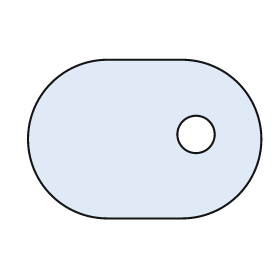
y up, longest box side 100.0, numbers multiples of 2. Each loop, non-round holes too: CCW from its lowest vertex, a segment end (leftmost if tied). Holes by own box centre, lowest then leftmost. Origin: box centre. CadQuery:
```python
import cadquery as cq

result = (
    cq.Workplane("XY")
    .moveTo(-16.0, -34.0)
    .lineTo(16.0, -34.0)
    .threePointArc((50.0, 0.0), (16.0, 34.0))
    .lineTo(-16.0, 34.0)
    .threePointArc((-50.0, 0.0), (-16.0, -34.0))
    .close()
    .moveTo(22.0, 2.0)
    .circle(8.0)
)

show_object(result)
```